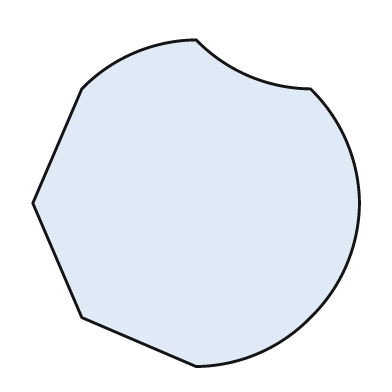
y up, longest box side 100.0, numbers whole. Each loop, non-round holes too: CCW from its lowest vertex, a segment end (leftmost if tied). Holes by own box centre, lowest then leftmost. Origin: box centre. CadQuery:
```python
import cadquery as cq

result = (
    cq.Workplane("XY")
    .moveTo(0.0, -50.0)
    .threePointArc((19.0, -46.0), (35.0, -35.0))
    .threePointArc((46.0, -19.0), (50.0, 0.0))
    .threePointArc((46.0, 19.0), (35.0, 35.0))
    .threePointArc((16.0, 39.0), (0.0, 50.0))
    .threePointArc((-19.0, 46.0), (-35.0, 35.0))
    .lineTo(-50.0, 0.0)
    .lineTo(-35.0, -35.0)
    .close()
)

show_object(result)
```